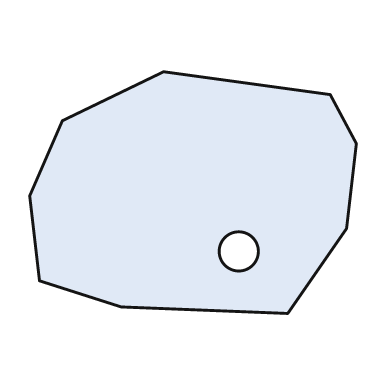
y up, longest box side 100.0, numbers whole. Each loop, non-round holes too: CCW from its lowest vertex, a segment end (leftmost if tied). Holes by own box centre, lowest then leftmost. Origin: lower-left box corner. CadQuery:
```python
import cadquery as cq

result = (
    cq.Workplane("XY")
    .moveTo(79.0, 0.0)
    .lineTo(97.0, 26.0)
    .lineTo(100.0, 52.0)
    .lineTo(92.0, 67.0)
    .lineTo(41.0, 74.0)
    .lineTo(10.0, 59.0)
    .lineTo(0.0, 36.0)
    .lineTo(3.0, 10.0)
    .lineTo(28.0, 2.0)
    .close()
    .moveTo(64.0, 19.0)
    .circle(6.0)
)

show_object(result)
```